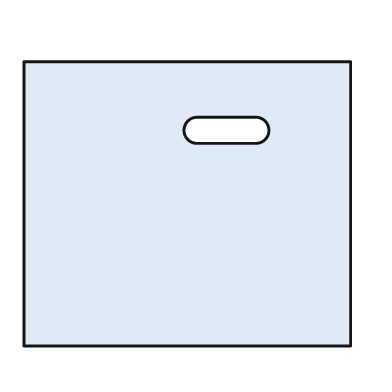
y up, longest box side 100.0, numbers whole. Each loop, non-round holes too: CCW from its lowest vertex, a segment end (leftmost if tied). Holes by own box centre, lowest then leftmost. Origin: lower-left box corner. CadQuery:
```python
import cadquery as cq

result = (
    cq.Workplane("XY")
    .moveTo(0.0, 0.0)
    .lineTo(100.0, 0.0)
    .lineTo(100.0, 87.0)
    .lineTo(0.0, 87.0)
    .close()
    .moveTo(53.0, 62.0)
    .lineTo(71.0, 62.0)
    .threePointArc((75.0, 66.0), (71.0, 70.0))
    .lineTo(53.0, 70.0)
    .threePointArc((49.0, 66.0), (53.0, 62.0))
    .close()
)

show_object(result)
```